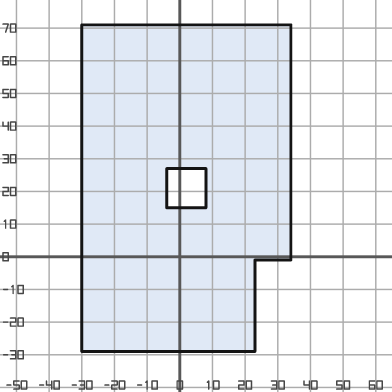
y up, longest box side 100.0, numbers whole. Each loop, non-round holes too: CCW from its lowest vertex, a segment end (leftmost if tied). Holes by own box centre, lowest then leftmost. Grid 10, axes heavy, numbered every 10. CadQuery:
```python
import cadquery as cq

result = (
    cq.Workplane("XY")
    .moveTo(-30.0, -29.0)
    .lineTo(23.0, -29.0)
    .lineTo(23.0, -1.0)
    .lineTo(34.0, -1.0)
    .lineTo(34.0, 71.0)
    .lineTo(-30.0, 71.0)
    .close()
    .moveTo(-4.0, 15.0)
    .lineTo(8.0, 15.0)
    .lineTo(8.0, 27.0)
    .lineTo(-4.0, 27.0)
    .close()
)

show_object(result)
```